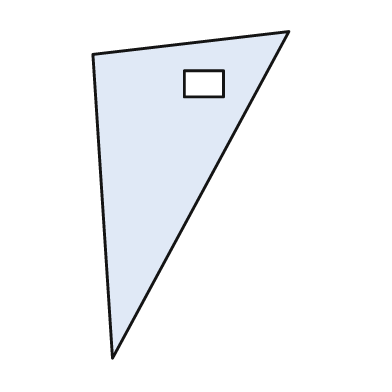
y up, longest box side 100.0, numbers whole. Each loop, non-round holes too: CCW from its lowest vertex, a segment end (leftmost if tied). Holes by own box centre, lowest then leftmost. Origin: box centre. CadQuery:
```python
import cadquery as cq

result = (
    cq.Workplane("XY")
    .moveTo(-24.0, -50.0)
    .lineTo(30.0, 50.0)
    .lineTo(-30.0, 43.0)
    .close()
    .moveTo(-2.0, 30.0)
    .lineTo(10.0, 30.0)
    .lineTo(10.0, 38.0)
    .lineTo(-2.0, 38.0)
    .close()
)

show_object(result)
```